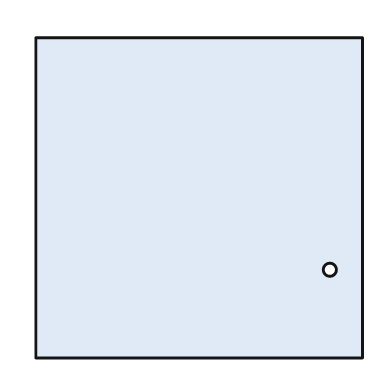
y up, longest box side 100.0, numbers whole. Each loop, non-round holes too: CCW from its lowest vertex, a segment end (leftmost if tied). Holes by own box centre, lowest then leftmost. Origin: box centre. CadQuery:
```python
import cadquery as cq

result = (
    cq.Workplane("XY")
    .moveTo(-50.0, -49.0)
    .lineTo(50.0, -49.0)
    .lineTo(50.0, 49.0)
    .lineTo(-50.0, 49.0)
    .close()
    .moveTo(40.0, -22.0)
    .circle(2.0)
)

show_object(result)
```